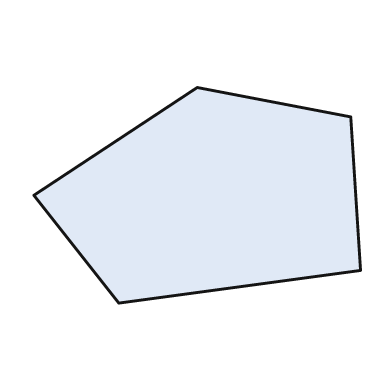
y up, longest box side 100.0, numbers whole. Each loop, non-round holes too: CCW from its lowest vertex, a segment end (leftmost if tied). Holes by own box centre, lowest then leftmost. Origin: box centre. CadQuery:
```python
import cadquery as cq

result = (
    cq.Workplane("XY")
    .moveTo(-24.0, -33.0)
    .lineTo(50.0, -23.0)
    .lineTo(47.0, 24.0)
    .lineTo(0.0, 33.0)
    .lineTo(-50.0, 0.0)
    .close()
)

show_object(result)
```